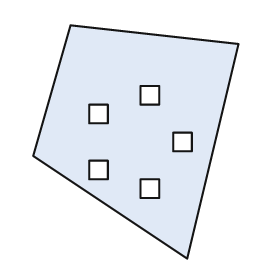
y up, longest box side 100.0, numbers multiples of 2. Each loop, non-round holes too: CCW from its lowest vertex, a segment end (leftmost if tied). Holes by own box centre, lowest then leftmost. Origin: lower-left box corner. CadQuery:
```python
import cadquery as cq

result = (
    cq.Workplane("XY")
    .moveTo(66.0, 0.0)
    .lineTo(88.0, 92.0)
    .lineTo(16.0, 100.0)
    .lineTo(0.0, 44.0)
    .close()
    .moveTo(46.0, 26.0)
    .lineTo(54.0, 26.0)
    .lineTo(54.0, 34.0)
    .lineTo(46.0, 34.0)
    .close()
    .moveTo(24.0, 34.0)
    .lineTo(32.0, 34.0)
    .lineTo(32.0, 42.0)
    .lineTo(24.0, 42.0)
    .close()
    .moveTo(60.0, 46.0)
    .lineTo(68.0, 46.0)
    .lineTo(68.0, 54.0)
    .lineTo(60.0, 54.0)
    .close()
    .moveTo(24.0, 58.0)
    .lineTo(32.0, 58.0)
    .lineTo(32.0, 66.0)
    .lineTo(24.0, 66.0)
    .close()
    .moveTo(46.0, 66.0)
    .lineTo(54.0, 66.0)
    .lineTo(54.0, 74.0)
    .lineTo(46.0, 74.0)
    .close()
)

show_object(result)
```